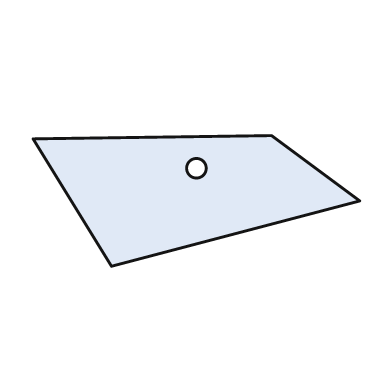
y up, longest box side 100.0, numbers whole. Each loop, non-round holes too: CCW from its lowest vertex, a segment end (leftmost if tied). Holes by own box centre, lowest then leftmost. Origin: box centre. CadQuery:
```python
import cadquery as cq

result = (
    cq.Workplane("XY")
    .moveTo(-26.0, -20.0)
    .lineTo(50.0, 0.0)
    .lineTo(23.0, 20.0)
    .lineTo(-50.0, 19.0)
    .close()
    .moveTo(0.0, 10.0)
    .circle(3.0)
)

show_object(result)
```